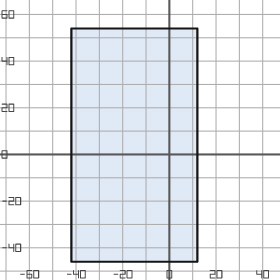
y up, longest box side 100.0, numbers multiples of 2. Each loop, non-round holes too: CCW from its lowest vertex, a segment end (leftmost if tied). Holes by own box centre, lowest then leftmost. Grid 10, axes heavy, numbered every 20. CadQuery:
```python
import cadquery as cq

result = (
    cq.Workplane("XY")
    .moveTo(-42.0, -46.0)
    .lineTo(12.0, -46.0)
    .lineTo(12.0, 54.0)
    .lineTo(-42.0, 54.0)
    .close()
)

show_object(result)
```